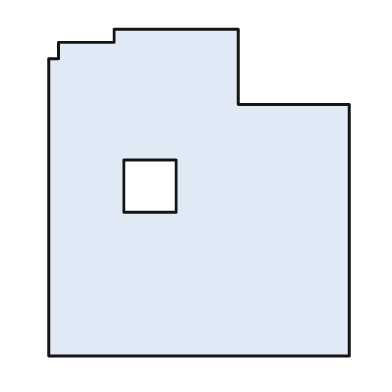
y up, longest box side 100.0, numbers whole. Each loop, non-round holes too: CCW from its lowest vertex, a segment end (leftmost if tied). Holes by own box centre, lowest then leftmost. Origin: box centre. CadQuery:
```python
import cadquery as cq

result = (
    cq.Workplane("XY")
    .moveTo(-46.0, -50.0)
    .lineTo(46.0, -50.0)
    .lineTo(46.0, 27.0)
    .lineTo(12.0, 27.0)
    .lineTo(12.0, 50.0)
    .lineTo(-26.0, 50.0)
    .lineTo(-26.0, 46.0)
    .lineTo(-43.0, 46.0)
    .lineTo(-43.0, 41.0)
    .lineTo(-46.0, 41.0)
    .close()
    .moveTo(-23.0, -6.0)
    .lineTo(-7.0, -6.0)
    .lineTo(-7.0, 10.0)
    .lineTo(-23.0, 10.0)
    .close()
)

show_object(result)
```